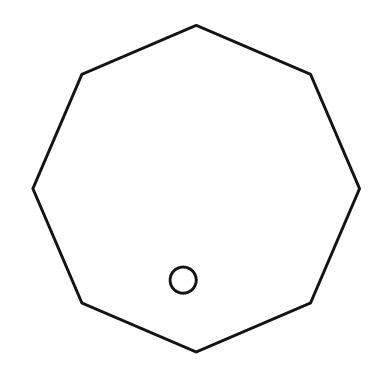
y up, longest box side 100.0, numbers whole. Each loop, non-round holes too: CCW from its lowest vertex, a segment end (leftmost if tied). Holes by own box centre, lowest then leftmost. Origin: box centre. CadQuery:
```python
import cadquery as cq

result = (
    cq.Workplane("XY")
    .moveTo(0.0, -50.0)
    .lineTo(35.0, -35.0)
    .lineTo(50.0, 0.0)
    .lineTo(35.0, 35.0)
    .lineTo(0.0, 50.0)
    .lineTo(-35.0, 35.0)
    .lineTo(-50.0, 0.0)
    .lineTo(-35.0, -35.0)
    .close()
    .moveTo(-4.0, -28.0)
    .circle(4.0)
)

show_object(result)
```